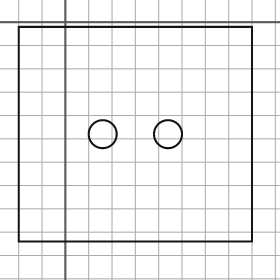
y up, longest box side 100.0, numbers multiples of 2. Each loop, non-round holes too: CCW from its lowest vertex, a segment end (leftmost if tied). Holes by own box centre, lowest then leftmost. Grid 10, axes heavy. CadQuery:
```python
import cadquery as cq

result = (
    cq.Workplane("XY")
    .moveTo(-20.0, -94.0)
    .lineTo(80.0, -94.0)
    .lineTo(80.0, -2.0)
    .lineTo(-20.0, -2.0)
    .close()
    .moveTo(16.0, -48.0)
    .circle(6.0)
    .moveTo(44.0, -48.0)
    .circle(6.0)
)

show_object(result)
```